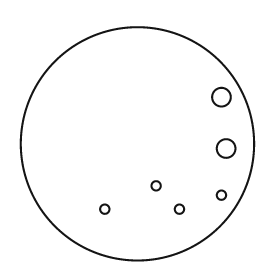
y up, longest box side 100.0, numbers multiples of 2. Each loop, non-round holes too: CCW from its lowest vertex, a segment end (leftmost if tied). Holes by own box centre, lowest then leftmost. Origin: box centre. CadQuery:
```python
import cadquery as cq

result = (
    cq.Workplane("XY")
    .moveTo(0.0, 0.0)
    .circle(50.0)
    .moveTo(-14.0, -28.0)
    .circle(2.0)
    .moveTo(18.0, -28.0)
    .circle(2.0)
    .moveTo(36.0, -22.0)
    .circle(2.0)
    .moveTo(8.0, -18.0)
    .circle(2.0)
    .moveTo(38.0, -2.0)
    .circle(4.0)
    .moveTo(36.0, 20.0)
    .circle(4.0)
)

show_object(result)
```